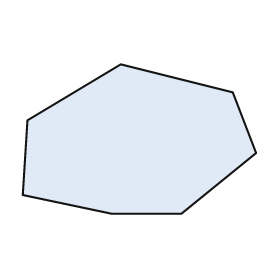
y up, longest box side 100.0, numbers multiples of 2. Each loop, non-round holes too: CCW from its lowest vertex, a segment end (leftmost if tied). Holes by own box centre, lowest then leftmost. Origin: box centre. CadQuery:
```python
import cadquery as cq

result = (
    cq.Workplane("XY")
    .moveTo(-12.0, -32.0)
    .lineTo(18.0, -32.0)
    .lineTo(50.0, -6.0)
    .lineTo(40.0, 20.0)
    .lineTo(-8.0, 32.0)
    .lineTo(-48.0, 8.0)
    .lineTo(-50.0, -24.0)
    .close()
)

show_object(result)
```